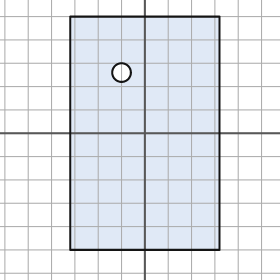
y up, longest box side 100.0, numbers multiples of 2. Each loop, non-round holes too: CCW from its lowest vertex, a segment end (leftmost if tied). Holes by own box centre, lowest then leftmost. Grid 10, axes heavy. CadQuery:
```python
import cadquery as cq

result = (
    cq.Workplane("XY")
    .moveTo(-32.0, -50.0)
    .lineTo(32.0, -50.0)
    .lineTo(32.0, 50.0)
    .lineTo(-32.0, 50.0)
    .close()
    .moveTo(-10.0, 26.0)
    .circle(4.0)
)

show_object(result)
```